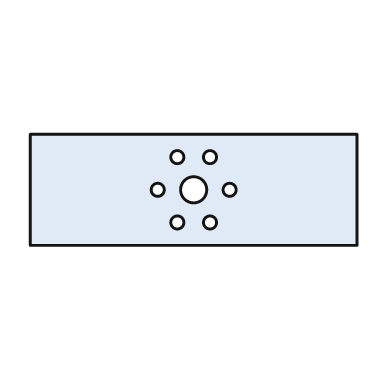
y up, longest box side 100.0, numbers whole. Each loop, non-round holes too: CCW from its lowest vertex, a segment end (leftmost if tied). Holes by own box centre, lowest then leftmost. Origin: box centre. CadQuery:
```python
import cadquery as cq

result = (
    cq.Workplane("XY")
    .moveTo(-50.0, -17.0)
    .lineTo(50.0, -17.0)
    .lineTo(50.0, 17.0)
    .lineTo(-50.0, 17.0)
    .close()
    .moveTo(-5.0, -10.0)
    .circle(2.0)
    .moveTo(5.0, -10.0)
    .circle(2.0)
    .moveTo(-11.0, 0.0)
    .circle(2.0)
    .moveTo(0.0, 0.0)
    .circle(4.0)
    .moveTo(11.0, 0.0)
    .circle(2.0)
    .moveTo(-5.0, 10.0)
    .circle(2.0)
    .moveTo(5.0, 10.0)
    .circle(2.0)
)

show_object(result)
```